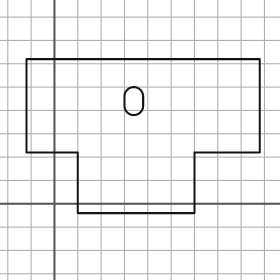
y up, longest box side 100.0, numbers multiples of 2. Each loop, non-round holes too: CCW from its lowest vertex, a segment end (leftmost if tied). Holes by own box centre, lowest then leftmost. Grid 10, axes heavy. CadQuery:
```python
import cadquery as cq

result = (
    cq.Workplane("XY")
    .moveTo(10.0, -4.0)
    .lineTo(60.0, -4.0)
    .lineTo(60.0, 22.0)
    .lineTo(88.0, 22.0)
    .lineTo(88.0, 62.0)
    .lineTo(-12.0, 62.0)
    .lineTo(-12.0, 22.0)
    .lineTo(10.0, 22.0)
    .close()
    .moveTo(30.0, 42.0)
    .threePointArc((34.0, 38.0), (38.0, 42.0))
    .lineTo(38.0, 46.0)
    .threePointArc((34.0, 50.0), (30.0, 46.0))
    .close()
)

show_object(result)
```